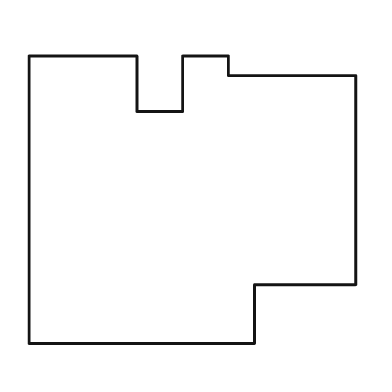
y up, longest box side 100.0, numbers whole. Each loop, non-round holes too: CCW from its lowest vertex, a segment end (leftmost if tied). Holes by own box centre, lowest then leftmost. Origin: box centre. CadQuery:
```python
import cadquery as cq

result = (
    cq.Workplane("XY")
    .moveTo(-50.0, -44.0)
    .lineTo(19.0, -44.0)
    .lineTo(19.0, -26.0)
    .lineTo(50.0, -26.0)
    .lineTo(50.0, 38.0)
    .lineTo(11.0, 38.0)
    .lineTo(11.0, 44.0)
    .lineTo(-3.0, 44.0)
    .lineTo(-3.0, 27.0)
    .lineTo(-17.0, 27.0)
    .lineTo(-17.0, 44.0)
    .lineTo(-50.0, 44.0)
    .close()
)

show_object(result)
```